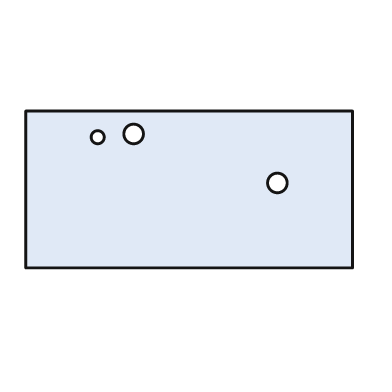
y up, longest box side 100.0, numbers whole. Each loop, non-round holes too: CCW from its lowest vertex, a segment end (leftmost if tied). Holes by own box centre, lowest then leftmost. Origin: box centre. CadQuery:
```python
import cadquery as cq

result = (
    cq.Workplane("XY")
    .moveTo(-50.0, -24.0)
    .lineTo(50.0, -24.0)
    .lineTo(50.0, 24.0)
    .lineTo(-50.0, 24.0)
    .close()
    .moveTo(27.0, 2.0)
    .circle(3.0)
    .moveTo(-28.0, 16.0)
    .circle(2.0)
    .moveTo(-17.0, 17.0)
    .circle(3.0)
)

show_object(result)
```